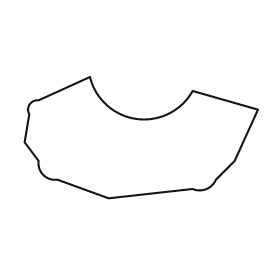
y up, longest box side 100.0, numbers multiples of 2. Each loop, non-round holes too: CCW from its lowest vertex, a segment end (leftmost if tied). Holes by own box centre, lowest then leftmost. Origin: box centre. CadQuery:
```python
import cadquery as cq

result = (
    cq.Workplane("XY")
    .moveTo(-14.0, -26.0)
    .lineTo(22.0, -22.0)
    .threePointArc((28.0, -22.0), (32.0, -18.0))
    .lineTo(40.0, -10.0)
    .lineTo(50.0, 12.0)
    .lineTo(22.0, 20.0)
    .threePointArc((-2.0, 8.0), (-22.0, 26.0))
    .lineTo(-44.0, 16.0)
    .threePointArc((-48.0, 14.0), (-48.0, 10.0))
    .lineTo(-50.0, -2.0)
    .lineTo(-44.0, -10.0)
    .threePointArc((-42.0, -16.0), (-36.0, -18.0))
    .close()
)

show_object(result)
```